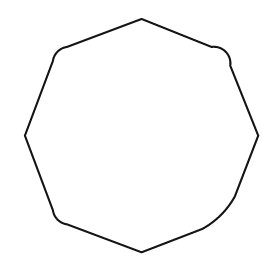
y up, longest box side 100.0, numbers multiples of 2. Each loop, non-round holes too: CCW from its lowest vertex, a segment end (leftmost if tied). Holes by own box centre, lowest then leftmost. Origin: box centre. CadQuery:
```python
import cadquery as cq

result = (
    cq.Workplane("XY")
    .moveTo(0.0, -50.0)
    .lineTo(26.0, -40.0)
    .threePointArc((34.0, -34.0), (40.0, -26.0))
    .lineTo(50.0, 0.0)
    .lineTo(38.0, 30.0)
    .threePointArc((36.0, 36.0), (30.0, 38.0))
    .lineTo(0.0, 50.0)
    .lineTo(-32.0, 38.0)
    .threePointArc((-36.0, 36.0), (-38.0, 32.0))
    .lineTo(-50.0, 0.0)
    .lineTo(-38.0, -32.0)
    .threePointArc((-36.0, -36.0), (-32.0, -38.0))
    .close()
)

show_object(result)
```